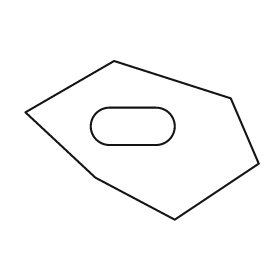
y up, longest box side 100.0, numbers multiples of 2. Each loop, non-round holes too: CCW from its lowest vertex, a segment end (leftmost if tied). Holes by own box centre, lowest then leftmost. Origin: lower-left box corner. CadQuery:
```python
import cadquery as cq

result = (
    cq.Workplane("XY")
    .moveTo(64.0, 0.0)
    .lineTo(100.0, 24.0)
    .lineTo(88.0, 52.0)
    .lineTo(38.0, 68.0)
    .lineTo(0.0, 46.0)
    .lineTo(30.0, 18.0)
    .close()
    .moveTo(36.0, 32.0)
    .lineTo(56.0, 32.0)
    .threePointArc((64.0, 40.0), (56.0, 48.0))
    .lineTo(36.0, 48.0)
    .threePointArc((28.0, 40.0), (36.0, 32.0))
    .close()
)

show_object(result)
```